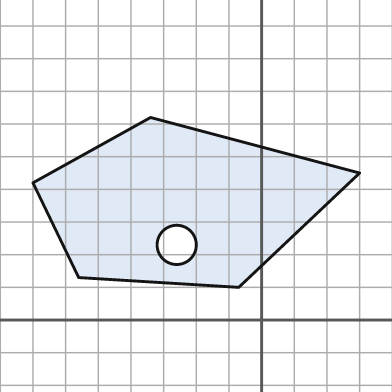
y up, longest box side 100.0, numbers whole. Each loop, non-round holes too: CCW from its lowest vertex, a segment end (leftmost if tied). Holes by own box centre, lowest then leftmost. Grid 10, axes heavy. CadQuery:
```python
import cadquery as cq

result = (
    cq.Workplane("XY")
    .moveTo(-7.0, 10.0)
    .lineTo(30.0, 45.0)
    .lineTo(-34.0, 62.0)
    .lineTo(-70.0, 42.0)
    .lineTo(-56.0, 13.0)
    .close()
    .moveTo(-26.0, 23.0)
    .circle(6.0)
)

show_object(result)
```